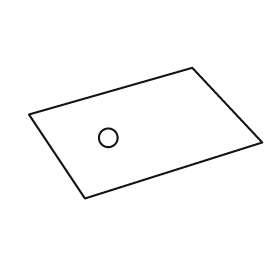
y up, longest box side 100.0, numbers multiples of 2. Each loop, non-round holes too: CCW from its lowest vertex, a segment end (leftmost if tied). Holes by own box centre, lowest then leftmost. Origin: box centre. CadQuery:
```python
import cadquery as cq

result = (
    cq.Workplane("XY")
    .moveTo(-26.0, -28.0)
    .lineTo(50.0, -4.0)
    .lineTo(20.0, 28.0)
    .lineTo(-50.0, 8.0)
    .close()
    .moveTo(-16.0, -2.0)
    .circle(4.0)
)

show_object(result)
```